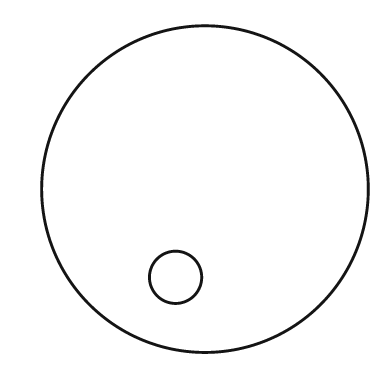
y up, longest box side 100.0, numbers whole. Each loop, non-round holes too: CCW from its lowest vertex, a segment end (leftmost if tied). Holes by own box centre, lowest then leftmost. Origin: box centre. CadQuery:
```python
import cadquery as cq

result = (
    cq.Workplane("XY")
    .moveTo(0.0, 0.0)
    .circle(50.0)
    .moveTo(-9.0, -27.0)
    .circle(8.0)
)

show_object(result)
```